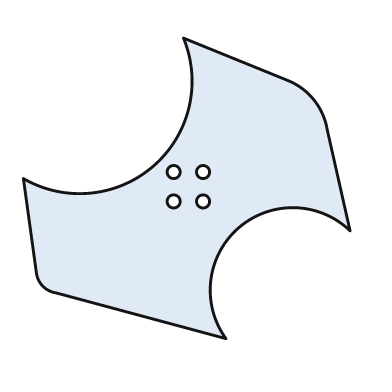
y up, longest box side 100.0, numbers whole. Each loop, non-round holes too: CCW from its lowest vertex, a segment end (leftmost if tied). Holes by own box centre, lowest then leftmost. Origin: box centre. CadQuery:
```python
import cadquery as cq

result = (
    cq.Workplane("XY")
    .moveTo(12.0, -46.0)
    .threePointArc((16.0, -12.0), (50.0, -13.0))
    .lineTo(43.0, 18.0)
    .threePointArc((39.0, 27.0), (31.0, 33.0))
    .lineTo(-1.0, 46.0)
    .threePointArc((-10.0, 7.0), (-50.0, 3.0))
    .lineTo(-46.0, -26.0)
    .threePointArc((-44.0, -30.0), (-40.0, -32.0))
    .close()
    .moveTo(-4.0, -4.0)
    .circle(2.0)
    .moveTo(5.0, -4.0)
    .circle(2.0)
    .moveTo(-4.0, 5.0)
    .circle(2.0)
    .moveTo(5.0, 5.0)
    .circle(2.0)
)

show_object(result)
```